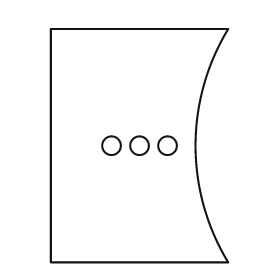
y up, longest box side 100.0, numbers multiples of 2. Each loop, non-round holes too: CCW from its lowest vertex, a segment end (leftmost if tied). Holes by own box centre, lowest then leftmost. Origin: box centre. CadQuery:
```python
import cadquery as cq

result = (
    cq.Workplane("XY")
    .moveTo(-38.0, -50.0)
    .lineTo(38.0, -50.0)
    .threePointArc((24.0, 0.0), (38.0, 50.0))
    .lineTo(-38.0, 50.0)
    .close()
    .moveTo(-12.0, 0.0)
    .circle(4.0)
    .moveTo(0.0, 0.0)
    .circle(4.0)
    .moveTo(12.0, 0.0)
    .circle(4.0)
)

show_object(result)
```